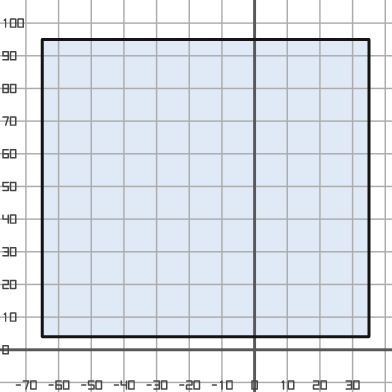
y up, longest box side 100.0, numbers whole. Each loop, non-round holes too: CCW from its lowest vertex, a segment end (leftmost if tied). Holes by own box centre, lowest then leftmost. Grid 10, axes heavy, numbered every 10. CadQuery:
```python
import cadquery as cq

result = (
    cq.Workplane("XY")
    .moveTo(-65.0, 4.0)
    .lineTo(35.0, 4.0)
    .lineTo(35.0, 95.0)
    .lineTo(-65.0, 95.0)
    .close()
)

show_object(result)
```